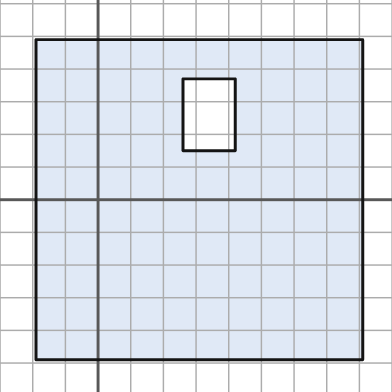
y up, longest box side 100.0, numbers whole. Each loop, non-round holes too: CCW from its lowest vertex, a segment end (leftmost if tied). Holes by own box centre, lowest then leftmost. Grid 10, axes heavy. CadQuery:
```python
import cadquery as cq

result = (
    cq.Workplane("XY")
    .moveTo(-19.0, -49.0)
    .lineTo(81.0, -49.0)
    .lineTo(81.0, 49.0)
    .lineTo(-19.0, 49.0)
    .close()
    .moveTo(26.0, 15.0)
    .lineTo(42.0, 15.0)
    .lineTo(42.0, 37.0)
    .lineTo(26.0, 37.0)
    .close()
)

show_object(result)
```